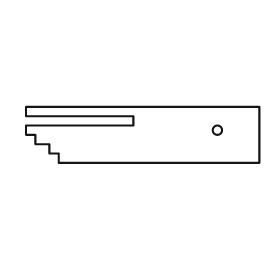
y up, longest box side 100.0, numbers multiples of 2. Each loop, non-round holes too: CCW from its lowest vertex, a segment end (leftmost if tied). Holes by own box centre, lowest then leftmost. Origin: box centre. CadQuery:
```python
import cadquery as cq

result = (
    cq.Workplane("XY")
    .moveTo(-36.0, -12.0)
    .lineTo(50.0, -12.0)
    .lineTo(50.0, 12.0)
    .lineTo(-50.0, 12.0)
    .lineTo(-50.0, 8.0)
    .lineTo(-4.0, 8.0)
    .lineTo(-4.0, 4.0)
    .lineTo(-50.0, 4.0)
    .lineTo(-50.0, 0.0)
    .lineTo(-46.0, 0.0)
    .lineTo(-46.0, -4.0)
    .lineTo(-40.0, -4.0)
    .lineTo(-40.0, -8.0)
    .lineTo(-36.0, -8.0)
    .close()
    .moveTo(32.0, 2.0)
    .circle(2.0)
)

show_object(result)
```